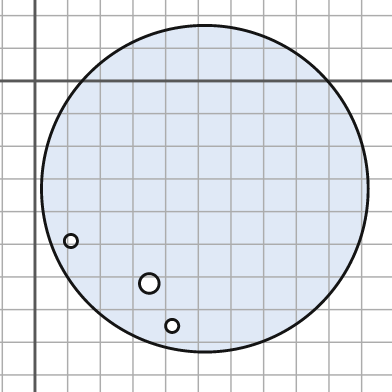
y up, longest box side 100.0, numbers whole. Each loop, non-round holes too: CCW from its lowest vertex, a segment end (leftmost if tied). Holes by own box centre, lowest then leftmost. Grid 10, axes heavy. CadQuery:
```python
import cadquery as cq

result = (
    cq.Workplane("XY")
    .moveTo(52.0, -33.0)
    .circle(50.0)
    .moveTo(42.0, -75.0)
    .circle(2.0)
    .moveTo(35.0, -62.0)
    .circle(3.0)
    .moveTo(11.0, -49.0)
    .circle(2.0)
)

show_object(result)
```